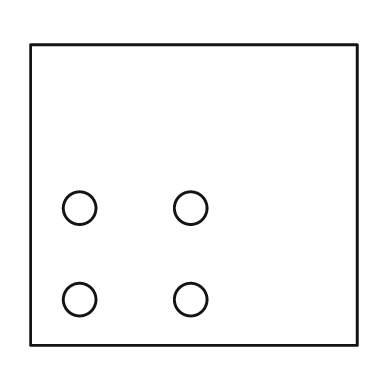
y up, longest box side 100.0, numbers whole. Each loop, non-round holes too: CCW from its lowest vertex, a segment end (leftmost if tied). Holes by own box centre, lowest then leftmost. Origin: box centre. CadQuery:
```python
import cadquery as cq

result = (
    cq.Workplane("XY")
    .moveTo(-50.0, -46.0)
    .lineTo(50.0, -46.0)
    .lineTo(50.0, 46.0)
    .lineTo(-50.0, 46.0)
    .close()
    .moveTo(-35.0, -32.0)
    .circle(5.0)
    .moveTo(-1.0, -32.0)
    .circle(5.0)
    .moveTo(-35.0, -4.0)
    .circle(5.0)
    .moveTo(-1.0, -4.0)
    .circle(5.0)
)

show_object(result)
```